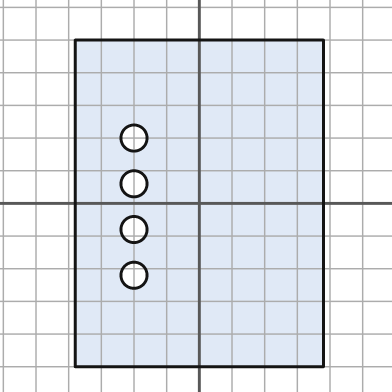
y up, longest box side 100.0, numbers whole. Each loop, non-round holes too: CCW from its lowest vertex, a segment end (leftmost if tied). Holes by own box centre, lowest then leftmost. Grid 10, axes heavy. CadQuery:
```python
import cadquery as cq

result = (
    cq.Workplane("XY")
    .moveTo(-38.0, -50.0)
    .lineTo(38.0, -50.0)
    .lineTo(38.0, 50.0)
    .lineTo(-38.0, 50.0)
    .close()
    .moveTo(-20.0, -22.0)
    .circle(4.0)
    .moveTo(-20.0, -8.0)
    .circle(4.0)
    .moveTo(-20.0, 6.0)
    .circle(4.0)
    .moveTo(-20.0, 20.0)
    .circle(4.0)
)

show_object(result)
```